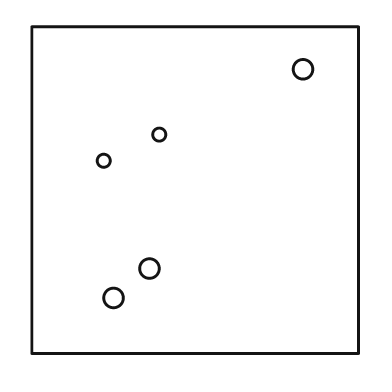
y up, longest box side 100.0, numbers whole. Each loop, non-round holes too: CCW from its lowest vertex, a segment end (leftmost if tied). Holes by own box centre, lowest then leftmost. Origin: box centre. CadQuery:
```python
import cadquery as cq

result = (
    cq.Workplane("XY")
    .moveTo(-50.0, -50.0)
    .lineTo(50.0, -50.0)
    .lineTo(50.0, 50.0)
    .lineTo(-50.0, 50.0)
    .close()
    .moveTo(-25.0, -33.0)
    .circle(3.0)
    .moveTo(-14.0, -24.0)
    .circle(3.0)
    .moveTo(-28.0, 9.0)
    .circle(2.0)
    .moveTo(-11.0, 17.0)
    .circle(2.0)
    .moveTo(33.0, 37.0)
    .circle(3.0)
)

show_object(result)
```